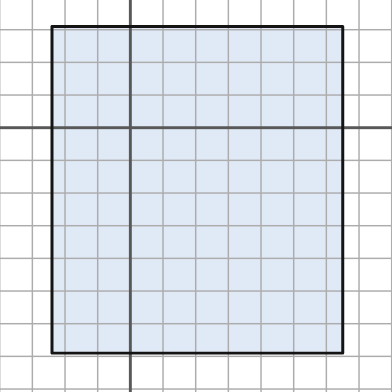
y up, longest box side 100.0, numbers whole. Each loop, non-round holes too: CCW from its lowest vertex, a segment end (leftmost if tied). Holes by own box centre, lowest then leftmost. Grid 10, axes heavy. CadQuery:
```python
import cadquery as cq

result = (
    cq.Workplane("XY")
    .moveTo(-24.0, -69.0)
    .lineTo(65.0, -69.0)
    .lineTo(65.0, 31.0)
    .lineTo(-24.0, 31.0)
    .close()
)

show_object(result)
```